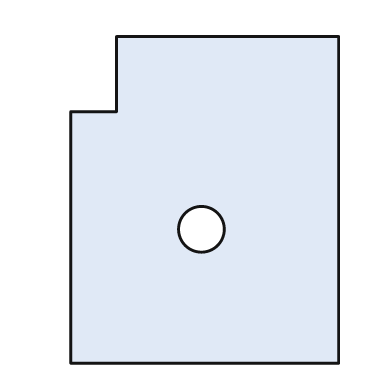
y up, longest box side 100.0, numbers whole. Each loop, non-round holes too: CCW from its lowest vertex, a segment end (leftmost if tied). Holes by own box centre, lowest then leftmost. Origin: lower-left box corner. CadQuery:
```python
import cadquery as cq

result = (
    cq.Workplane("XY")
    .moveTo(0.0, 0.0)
    .lineTo(82.0, 0.0)
    .lineTo(82.0, 100.0)
    .lineTo(14.0, 100.0)
    .lineTo(14.0, 77.0)
    .lineTo(0.0, 77.0)
    .close()
    .moveTo(40.0, 41.0)
    .circle(7.0)
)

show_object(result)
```